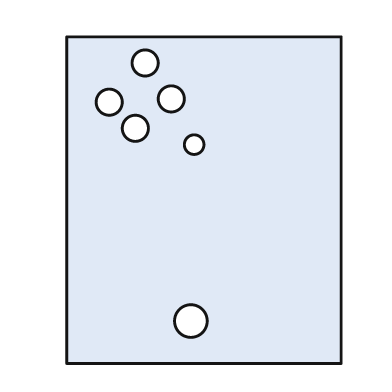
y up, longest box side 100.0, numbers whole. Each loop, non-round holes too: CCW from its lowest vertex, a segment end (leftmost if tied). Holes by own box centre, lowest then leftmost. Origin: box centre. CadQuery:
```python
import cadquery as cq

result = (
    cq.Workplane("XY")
    .moveTo(-42.0, -50.0)
    .lineTo(42.0, -50.0)
    .lineTo(42.0, 50.0)
    .lineTo(-42.0, 50.0)
    .close()
    .moveTo(-4.0, -37.0)
    .circle(5.0)
    .moveTo(-3.0, 17.0)
    .circle(3.0)
    .moveTo(-21.0, 22.0)
    .circle(4.0)
    .moveTo(-29.0, 30.0)
    .circle(4.0)
    .moveTo(-10.0, 31.0)
    .circle(4.0)
    .moveTo(-18.0, 42.0)
    .circle(4.0)
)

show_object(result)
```